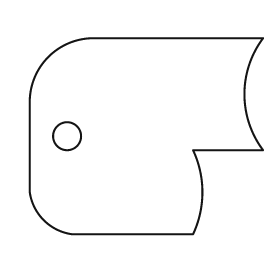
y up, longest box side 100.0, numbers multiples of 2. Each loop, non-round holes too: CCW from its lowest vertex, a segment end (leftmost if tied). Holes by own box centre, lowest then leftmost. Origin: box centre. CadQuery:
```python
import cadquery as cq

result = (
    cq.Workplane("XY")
    .moveTo(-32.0, -42.0)
    .lineTo(20.0, -42.0)
    .threePointArc((24.0, -24.0), (20.0, -6.0))
    .lineTo(50.0, -6.0)
    .threePointArc((42.0, 18.0), (50.0, 42.0))
    .lineTo(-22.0, 42.0)
    .threePointArc((-42.0, 34.0), (-50.0, 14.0))
    .lineTo(-50.0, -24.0)
    .threePointArc((-44.0, -36.0), (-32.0, -42.0))
    .close()
    .moveTo(-34.0, 0.0)
    .circle(6.0)
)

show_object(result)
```